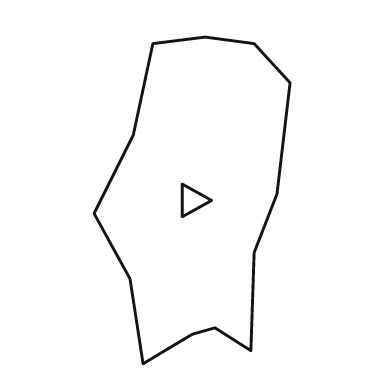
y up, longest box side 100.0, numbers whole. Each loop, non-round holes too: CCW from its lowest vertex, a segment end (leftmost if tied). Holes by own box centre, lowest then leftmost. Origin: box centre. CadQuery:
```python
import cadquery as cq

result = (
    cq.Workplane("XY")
    .moveTo(-15.0, -50.0)
    .lineTo(0.0, -41.0)
    .lineTo(7.0, -39.0)
    .lineTo(18.0, -46.0)
    .lineTo(19.0, -16.0)
    .lineTo(26.0, 2.0)
    .lineTo(30.0, 36.0)
    .lineTo(19.0, 48.0)
    .lineTo(4.0, 50.0)
    .lineTo(-12.0, 48.0)
    .lineTo(-18.0, 20.0)
    .lineTo(-30.0, -4.0)
    .lineTo(-19.0, -24.0)
    .close()
    .moveTo(-3.0, -5.0)
    .lineTo(6.0, 0.0)
    .lineTo(-3.0, 5.0)
    .close()
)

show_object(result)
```